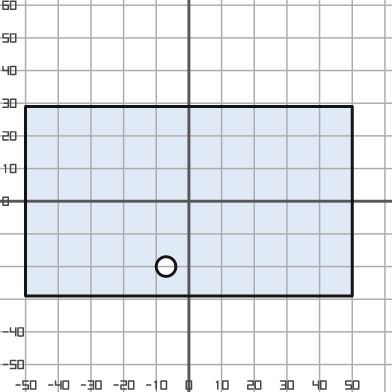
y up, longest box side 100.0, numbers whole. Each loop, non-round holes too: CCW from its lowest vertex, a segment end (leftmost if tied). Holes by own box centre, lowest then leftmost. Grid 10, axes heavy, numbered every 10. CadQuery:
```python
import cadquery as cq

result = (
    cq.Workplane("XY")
    .moveTo(-50.0, -29.0)
    .lineTo(50.0, -29.0)
    .lineTo(50.0, 29.0)
    .lineTo(-50.0, 29.0)
    .close()
    .moveTo(-7.0, -20.0)
    .circle(3.0)
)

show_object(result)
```